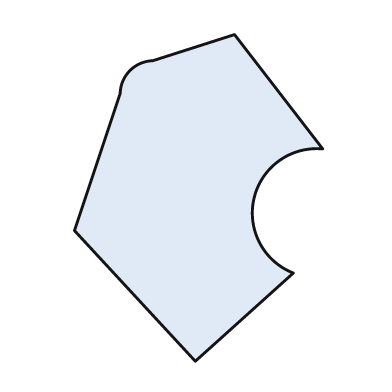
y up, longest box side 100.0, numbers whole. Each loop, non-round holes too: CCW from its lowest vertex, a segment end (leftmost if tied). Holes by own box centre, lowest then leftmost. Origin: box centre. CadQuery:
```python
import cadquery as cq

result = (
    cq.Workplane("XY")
    .moveTo(-1.0, -50.0)
    .lineTo(29.0, -23.0)
    .threePointArc((17.0, 0.0), (38.0, 15.0))
    .lineTo(11.0, 50.0)
    .lineTo(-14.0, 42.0)
    .threePointArc((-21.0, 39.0), (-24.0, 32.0))
    .lineTo(-38.0, -10.0)
    .close()
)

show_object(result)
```